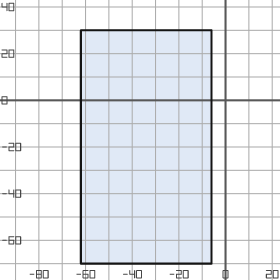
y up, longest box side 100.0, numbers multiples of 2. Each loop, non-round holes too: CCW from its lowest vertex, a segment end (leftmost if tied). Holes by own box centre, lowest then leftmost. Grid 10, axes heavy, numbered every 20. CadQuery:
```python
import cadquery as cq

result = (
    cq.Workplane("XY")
    .moveTo(-62.0, -70.0)
    .lineTo(-6.0, -70.0)
    .lineTo(-6.0, 30.0)
    .lineTo(-62.0, 30.0)
    .close()
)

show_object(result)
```